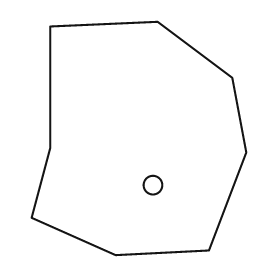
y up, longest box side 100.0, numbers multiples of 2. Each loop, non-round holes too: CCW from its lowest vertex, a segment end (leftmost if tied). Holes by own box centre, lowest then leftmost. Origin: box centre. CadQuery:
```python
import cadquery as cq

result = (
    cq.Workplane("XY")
    .moveTo(-10.0, -50.0)
    .lineTo(30.0, -48.0)
    .lineTo(46.0, -6.0)
    .lineTo(40.0, 26.0)
    .lineTo(8.0, 50.0)
    .lineTo(-38.0, 48.0)
    .lineTo(-38.0, -4.0)
    .lineTo(-46.0, -34.0)
    .close()
    .moveTo(6.0, -20.0)
    .circle(4.0)
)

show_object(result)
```